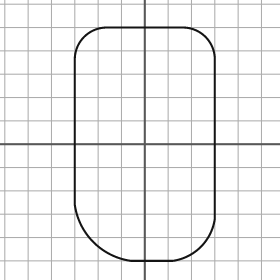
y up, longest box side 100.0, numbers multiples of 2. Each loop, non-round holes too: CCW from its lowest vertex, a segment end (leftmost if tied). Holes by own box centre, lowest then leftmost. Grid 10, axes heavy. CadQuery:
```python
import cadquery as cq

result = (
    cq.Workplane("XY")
    .moveTo(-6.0, -50.0)
    .lineTo(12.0, -50.0)
    .threePointArc((24.0, -44.0), (30.0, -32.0))
    .lineTo(30.0, 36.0)
    .threePointArc((26.0, 46.0), (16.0, 50.0))
    .lineTo(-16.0, 50.0)
    .threePointArc((-26.0, 46.0), (-30.0, 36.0))
    .lineTo(-30.0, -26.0)
    .threePointArc((-22.0, -42.0), (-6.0, -50.0))
    .close()
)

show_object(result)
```